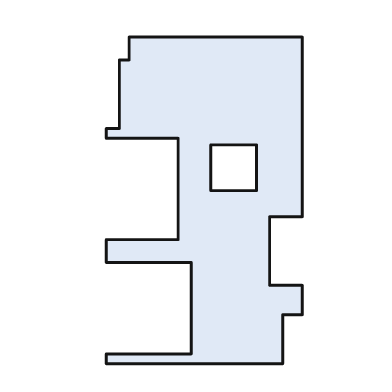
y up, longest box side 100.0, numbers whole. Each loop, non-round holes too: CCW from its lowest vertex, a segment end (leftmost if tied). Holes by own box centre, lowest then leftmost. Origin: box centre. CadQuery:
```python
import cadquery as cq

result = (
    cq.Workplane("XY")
    .moveTo(-30.0, -50.0)
    .lineTo(24.0, -50.0)
    .lineTo(24.0, -35.0)
    .lineTo(30.0, -35.0)
    .lineTo(30.0, -26.0)
    .lineTo(20.0, -26.0)
    .lineTo(20.0, -5.0)
    .lineTo(30.0, -5.0)
    .lineTo(30.0, 50.0)
    .lineTo(-23.0, 50.0)
    .lineTo(-23.0, 43.0)
    .lineTo(-26.0, 43.0)
    .lineTo(-26.0, 22.0)
    .lineTo(-30.0, 22.0)
    .lineTo(-30.0, 19.0)
    .lineTo(-8.0, 19.0)
    .lineTo(-8.0, -12.0)
    .lineTo(-30.0, -12.0)
    .lineTo(-30.0, -19.0)
    .lineTo(-4.0, -19.0)
    .lineTo(-4.0, -47.0)
    .lineTo(-30.0, -47.0)
    .close()
    .moveTo(2.0, 3.0)
    .lineTo(16.0, 3.0)
    .lineTo(16.0, 17.0)
    .lineTo(2.0, 17.0)
    .close()
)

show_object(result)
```